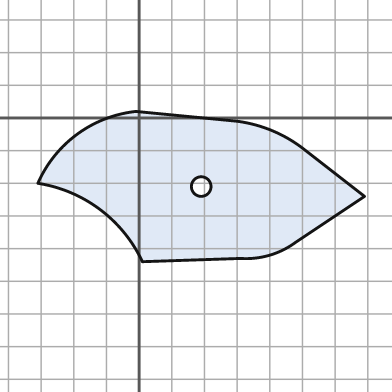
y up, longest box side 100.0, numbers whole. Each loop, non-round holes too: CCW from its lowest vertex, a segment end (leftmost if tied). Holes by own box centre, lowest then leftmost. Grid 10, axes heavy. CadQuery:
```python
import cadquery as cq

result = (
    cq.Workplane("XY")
    .moveTo(1.0, -44.0)
    .lineTo(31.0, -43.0)
    .threePointArc((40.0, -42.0), (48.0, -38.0))
    .lineTo(69.0, -24.0)
    .lineTo(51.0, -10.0)
    .threePointArc((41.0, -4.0), (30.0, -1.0))
    .lineTo(-1.0, 2.0)
    .threePointArc((-19.0, -5.0), (-31.0, -20.0))
    .threePointArc((-12.0, -28.0), (1.0, -44.0))
    .close()
    .moveTo(19.0, -21.0)
    .circle(3.0)
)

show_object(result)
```